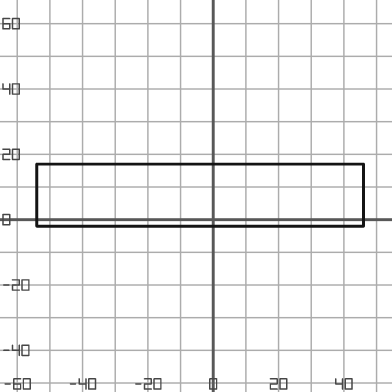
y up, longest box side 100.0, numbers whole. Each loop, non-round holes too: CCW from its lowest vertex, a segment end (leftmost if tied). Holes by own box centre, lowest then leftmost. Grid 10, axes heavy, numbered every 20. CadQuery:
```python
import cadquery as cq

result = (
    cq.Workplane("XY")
    .moveTo(-54.0, -2.0)
    .lineTo(46.0, -2.0)
    .lineTo(46.0, 17.0)
    .lineTo(-54.0, 17.0)
    .close()
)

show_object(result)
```